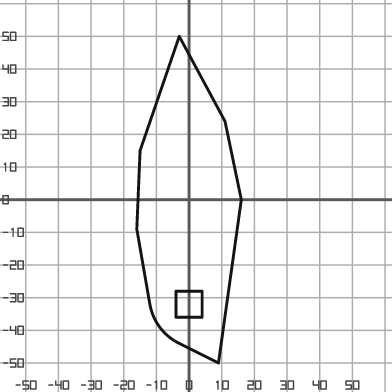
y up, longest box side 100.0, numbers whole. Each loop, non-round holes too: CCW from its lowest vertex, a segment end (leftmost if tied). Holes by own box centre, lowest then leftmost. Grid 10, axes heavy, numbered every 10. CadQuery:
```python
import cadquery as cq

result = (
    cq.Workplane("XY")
    .moveTo(9.0, -50.0)
    .lineTo(16.0, 0.0)
    .lineTo(11.0, 24.0)
    .lineTo(-3.0, 50.0)
    .lineTo(-15.0, 15.0)
    .lineTo(-16.0, -9.0)
    .lineTo(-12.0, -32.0)
    .threePointArc((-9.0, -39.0), (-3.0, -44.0))
    .close()
    .moveTo(-4.0, -36.0)
    .lineTo(4.0, -36.0)
    .lineTo(4.0, -28.0)
    .lineTo(-4.0, -28.0)
    .close()
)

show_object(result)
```